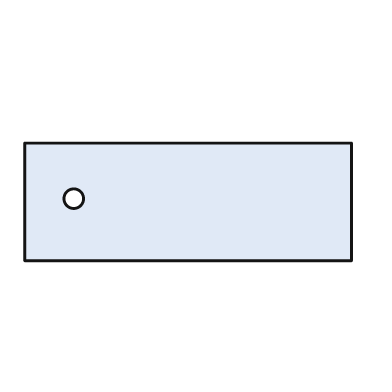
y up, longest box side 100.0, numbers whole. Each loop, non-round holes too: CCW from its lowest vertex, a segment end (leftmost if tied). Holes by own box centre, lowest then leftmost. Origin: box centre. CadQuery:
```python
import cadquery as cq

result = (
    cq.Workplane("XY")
    .moveTo(-50.0, -18.0)
    .lineTo(50.0, -18.0)
    .lineTo(50.0, 18.0)
    .lineTo(-50.0, 18.0)
    .close()
    .moveTo(-35.0, 1.0)
    .circle(3.0)
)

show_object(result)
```